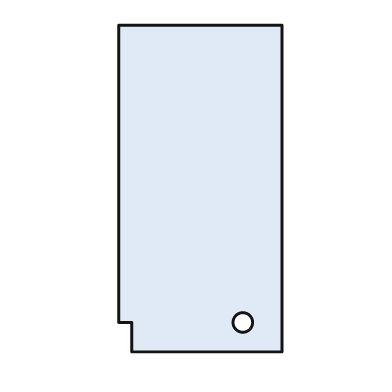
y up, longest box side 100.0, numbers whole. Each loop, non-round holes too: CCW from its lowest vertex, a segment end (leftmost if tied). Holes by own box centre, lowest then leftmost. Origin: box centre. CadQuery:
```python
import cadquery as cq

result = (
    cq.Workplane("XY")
    .moveTo(-21.0, -50.0)
    .lineTo(25.0, -50.0)
    .lineTo(25.0, 50.0)
    .lineTo(-25.0, 50.0)
    .lineTo(-25.0, -41.0)
    .lineTo(-21.0, -41.0)
    .close()
    .moveTo(13.0, -41.0)
    .circle(3.0)
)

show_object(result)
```